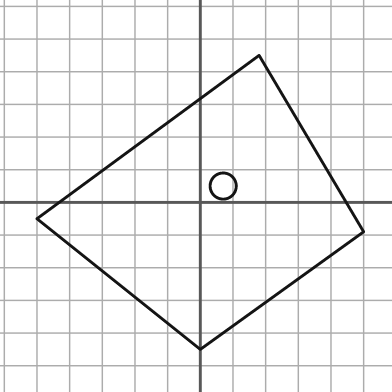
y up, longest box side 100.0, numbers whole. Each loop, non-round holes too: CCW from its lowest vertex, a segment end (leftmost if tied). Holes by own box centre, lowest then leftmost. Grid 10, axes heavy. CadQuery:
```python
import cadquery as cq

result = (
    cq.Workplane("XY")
    .moveTo(0.0, -45.0)
    .lineTo(50.0, -9.0)
    .lineTo(18.0, 45.0)
    .lineTo(-50.0, -5.0)
    .close()
    .moveTo(7.0, 5.0)
    .circle(4.0)
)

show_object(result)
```